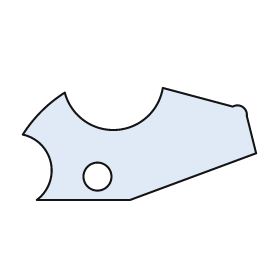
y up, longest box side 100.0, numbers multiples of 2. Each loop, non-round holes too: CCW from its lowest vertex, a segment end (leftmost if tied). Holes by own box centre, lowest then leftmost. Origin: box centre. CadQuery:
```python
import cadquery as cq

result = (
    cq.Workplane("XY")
    .moveTo(-44.0, -24.0)
    .lineTo(-4.0, -24.0)
    .lineTo(50.0, -4.0)
    .lineTo(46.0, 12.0)
    .threePointArc((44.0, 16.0), (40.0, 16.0))
    .lineTo(10.0, 24.0)
    .threePointArc((-10.0, 6.0), (-32.0, 22.0))
    .threePointArc((-42.0, 14.0), (-50.0, 4.0))
    .threePointArc((-38.0, -8.0), (-44.0, -24.0))
    .close()
    .moveTo(-18.0, -14.0)
    .circle(6.0)
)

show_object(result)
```